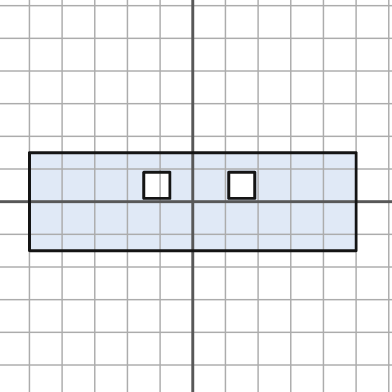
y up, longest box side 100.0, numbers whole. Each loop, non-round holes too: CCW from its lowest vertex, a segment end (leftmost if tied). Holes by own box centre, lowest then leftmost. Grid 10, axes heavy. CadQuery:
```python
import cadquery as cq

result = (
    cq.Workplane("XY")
    .moveTo(-50.0, -15.0)
    .lineTo(50.0, -15.0)
    .lineTo(50.0, 15.0)
    .lineTo(-50.0, 15.0)
    .close()
    .moveTo(-15.0, 1.0)
    .lineTo(-7.0, 1.0)
    .lineTo(-7.0, 9.0)
    .lineTo(-15.0, 9.0)
    .close()
    .moveTo(11.0, 1.0)
    .lineTo(19.0, 1.0)
    .lineTo(19.0, 9.0)
    .lineTo(11.0, 9.0)
    .close()
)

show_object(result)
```